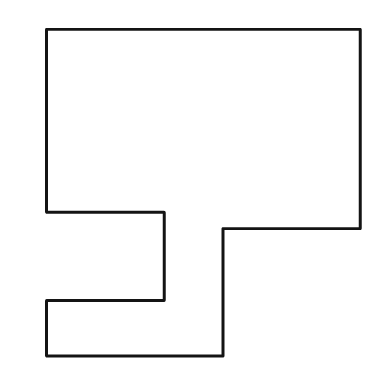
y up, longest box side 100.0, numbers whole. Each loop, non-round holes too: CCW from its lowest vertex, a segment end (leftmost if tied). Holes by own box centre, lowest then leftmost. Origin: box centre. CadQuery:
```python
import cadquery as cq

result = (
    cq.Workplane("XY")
    .moveTo(-48.0, -50.0)
    .lineTo(6.0, -50.0)
    .lineTo(6.0, -11.0)
    .lineTo(48.0, -11.0)
    .lineTo(48.0, 50.0)
    .lineTo(-48.0, 50.0)
    .lineTo(-48.0, -6.0)
    .lineTo(-12.0, -6.0)
    .lineTo(-12.0, -33.0)
    .lineTo(-48.0, -33.0)
    .close()
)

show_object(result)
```